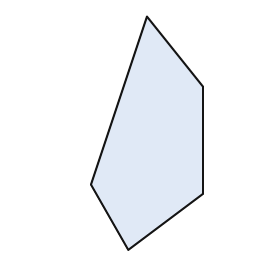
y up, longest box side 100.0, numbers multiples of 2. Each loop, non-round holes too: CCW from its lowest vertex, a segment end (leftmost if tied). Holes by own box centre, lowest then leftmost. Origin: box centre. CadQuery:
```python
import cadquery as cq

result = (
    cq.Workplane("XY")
    .moveTo(-8.0, -50.0)
    .lineTo(24.0, -26.0)
    .lineTo(24.0, 20.0)
    .lineTo(0.0, 50.0)
    .lineTo(-24.0, -22.0)
    .close()
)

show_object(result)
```